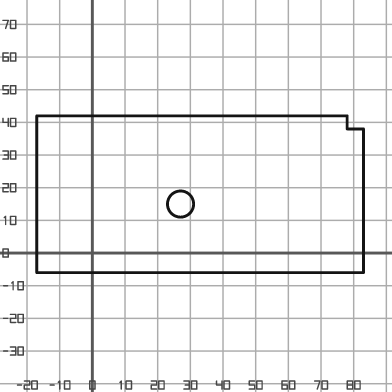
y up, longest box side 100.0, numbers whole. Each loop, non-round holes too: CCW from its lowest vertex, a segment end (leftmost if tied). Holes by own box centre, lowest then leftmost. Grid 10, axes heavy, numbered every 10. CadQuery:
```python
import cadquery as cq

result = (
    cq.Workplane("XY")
    .moveTo(-17.0, -6.0)
    .lineTo(83.0, -6.0)
    .lineTo(83.0, 38.0)
    .lineTo(78.0, 38.0)
    .lineTo(78.0, 42.0)
    .lineTo(-17.0, 42.0)
    .close()
    .moveTo(27.0, 15.0)
    .circle(4.0)
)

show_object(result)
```